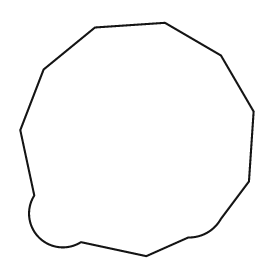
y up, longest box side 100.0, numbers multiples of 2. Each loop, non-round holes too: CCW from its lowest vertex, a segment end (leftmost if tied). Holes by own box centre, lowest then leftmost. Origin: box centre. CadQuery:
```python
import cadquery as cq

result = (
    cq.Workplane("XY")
    .moveTo(4.0, -50.0)
    .lineTo(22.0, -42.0)
    .threePointArc((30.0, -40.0), (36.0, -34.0))
    .lineTo(48.0, -18.0)
    .lineTo(50.0, 12.0)
    .lineTo(36.0, 36.0)
    .lineTo(12.0, 50.0)
    .lineTo(-18.0, 48.0)
    .lineTo(-40.0, 30.0)
    .lineTo(-50.0, 4.0)
    .lineTo(-44.0, -24.0)
    .threePointArc((-42.0, -42.0), (-24.0, -44.0))
    .close()
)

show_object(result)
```